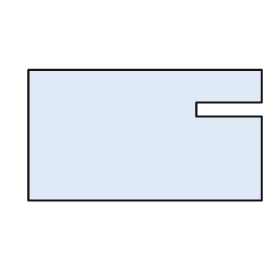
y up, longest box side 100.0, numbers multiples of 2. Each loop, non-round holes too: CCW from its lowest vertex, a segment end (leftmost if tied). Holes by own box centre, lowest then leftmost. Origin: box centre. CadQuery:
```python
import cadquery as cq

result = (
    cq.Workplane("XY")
    .moveTo(-50.0, -28.0)
    .lineTo(50.0, -28.0)
    .lineTo(50.0, 8.0)
    .lineTo(22.0, 8.0)
    .lineTo(22.0, 14.0)
    .lineTo(50.0, 14.0)
    .lineTo(50.0, 28.0)
    .lineTo(-50.0, 28.0)
    .close()
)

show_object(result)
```